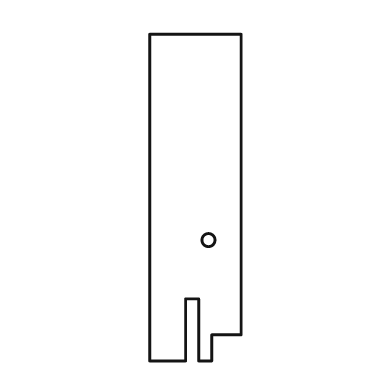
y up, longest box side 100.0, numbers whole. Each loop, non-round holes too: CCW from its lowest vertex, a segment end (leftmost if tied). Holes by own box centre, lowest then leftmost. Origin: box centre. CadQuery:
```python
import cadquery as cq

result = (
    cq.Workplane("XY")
    .moveTo(-14.0, -50.0)
    .lineTo(-3.0, -50.0)
    .lineTo(-3.0, -31.0)
    .lineTo(1.0, -31.0)
    .lineTo(1.0, -50.0)
    .lineTo(5.0, -50.0)
    .lineTo(5.0, -42.0)
    .lineTo(14.0, -42.0)
    .lineTo(14.0, 50.0)
    .lineTo(-14.0, 50.0)
    .close()
    .moveTo(4.0, -13.0)
    .circle(2.0)
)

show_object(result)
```